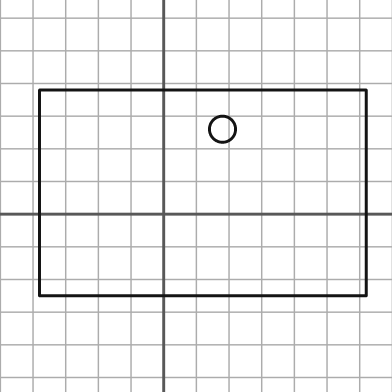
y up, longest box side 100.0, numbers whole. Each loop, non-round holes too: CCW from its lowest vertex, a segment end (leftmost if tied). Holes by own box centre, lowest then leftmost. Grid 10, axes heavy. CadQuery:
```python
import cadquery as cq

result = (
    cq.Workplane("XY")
    .moveTo(-38.0, -25.0)
    .lineTo(62.0, -25.0)
    .lineTo(62.0, 38.0)
    .lineTo(-38.0, 38.0)
    .close()
    .moveTo(18.0, 26.0)
    .circle(4.0)
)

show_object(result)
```